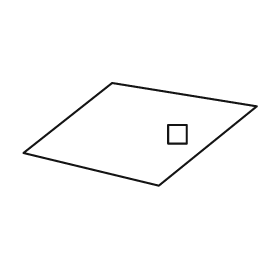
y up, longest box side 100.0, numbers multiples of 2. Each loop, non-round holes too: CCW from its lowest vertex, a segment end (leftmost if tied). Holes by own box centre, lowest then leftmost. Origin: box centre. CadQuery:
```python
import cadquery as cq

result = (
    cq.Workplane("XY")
    .moveTo(8.0, -22.0)
    .lineTo(50.0, 12.0)
    .lineTo(-12.0, 22.0)
    .lineTo(-50.0, -8.0)
    .close()
    .moveTo(12.0, -4.0)
    .lineTo(20.0, -4.0)
    .lineTo(20.0, 4.0)
    .lineTo(12.0, 4.0)
    .close()
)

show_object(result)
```